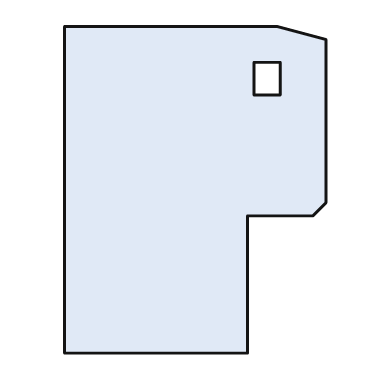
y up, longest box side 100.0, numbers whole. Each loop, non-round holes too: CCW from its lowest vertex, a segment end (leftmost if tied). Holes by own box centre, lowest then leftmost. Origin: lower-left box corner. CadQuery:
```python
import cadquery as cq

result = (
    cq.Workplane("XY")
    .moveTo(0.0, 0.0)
    .lineTo(56.0, 0.0)
    .lineTo(56.0, 42.0)
    .lineTo(76.0, 42.0)
    .lineTo(80.0, 46.0)
    .lineTo(80.0, 96.0)
    .lineTo(65.0, 100.0)
    .lineTo(0.0, 100.0)
    .close()
    .moveTo(58.0, 79.0)
    .lineTo(66.0, 79.0)
    .lineTo(66.0, 89.0)
    .lineTo(58.0, 89.0)
    .close()
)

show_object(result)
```